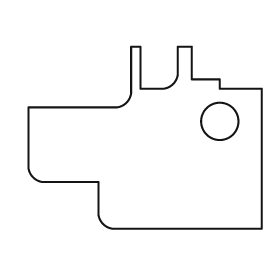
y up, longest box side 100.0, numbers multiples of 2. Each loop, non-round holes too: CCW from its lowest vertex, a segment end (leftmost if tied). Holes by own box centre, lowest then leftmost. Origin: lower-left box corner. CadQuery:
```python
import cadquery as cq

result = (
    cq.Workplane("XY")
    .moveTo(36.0, 0.0)
    .lineTo(100.0, 0.0)
    .lineTo(100.0, 60.0)
    .lineTo(82.0, 60.0)
    .lineTo(82.0, 64.0)
    .lineTo(70.0, 64.0)
    .lineTo(70.0, 78.0)
    .lineTo(64.0, 78.0)
    .lineTo(64.0, 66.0)
    .threePointArc((62.0, 62.0), (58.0, 60.0))
    .lineTo(48.0, 60.0)
    .lineTo(48.0, 78.0)
    .lineTo(44.0, 78.0)
    .lineTo(44.0, 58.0)
    .threePointArc((42.0, 54.0), (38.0, 52.0))
    .lineTo(0.0, 52.0)
    .lineTo(0.0, 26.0)
    .threePointArc((2.0, 22.0), (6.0, 20.0))
    .lineTo(30.0, 20.0)
    .lineTo(30.0, 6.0)
    .threePointArc((32.0, 2.0), (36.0, 0.0))
    .close()
    .moveTo(82.0, 46.0)
    .circle(8.0)
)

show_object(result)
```